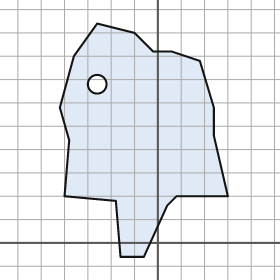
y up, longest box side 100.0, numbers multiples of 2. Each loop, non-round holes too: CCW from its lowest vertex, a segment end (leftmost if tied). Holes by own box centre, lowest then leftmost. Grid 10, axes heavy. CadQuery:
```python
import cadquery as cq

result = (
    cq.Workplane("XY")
    .moveTo(-16.0, -6.0)
    .lineTo(-6.0, -6.0)
    .lineTo(4.0, 16.0)
    .lineTo(8.0, 20.0)
    .lineTo(30.0, 20.0)
    .lineTo(24.0, 46.0)
    .lineTo(24.0, 58.0)
    .lineTo(18.0, 78.0)
    .lineTo(6.0, 82.0)
    .lineTo(-2.0, 82.0)
    .lineTo(-10.0, 90.0)
    .lineTo(-26.0, 94.0)
    .lineTo(-36.0, 80.0)
    .lineTo(-42.0, 58.0)
    .lineTo(-38.0, 44.0)
    .lineTo(-40.0, 20.0)
    .lineTo(-18.0, 18.0)
    .close()
    .moveTo(-26.0, 68.0)
    .circle(4.0)
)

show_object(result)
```